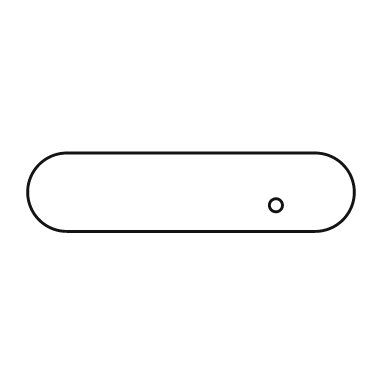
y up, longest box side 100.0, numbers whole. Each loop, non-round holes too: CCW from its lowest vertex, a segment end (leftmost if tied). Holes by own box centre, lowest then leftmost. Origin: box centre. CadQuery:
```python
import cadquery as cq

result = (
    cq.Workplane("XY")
    .moveTo(-38.0, -12.0)
    .lineTo(38.0, -12.0)
    .threePointArc((50.0, 0.0), (38.0, 12.0))
    .lineTo(-38.0, 12.0)
    .threePointArc((-50.0, 0.0), (-38.0, -12.0))
    .close()
    .moveTo(26.0, -4.0)
    .circle(2.0)
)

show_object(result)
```